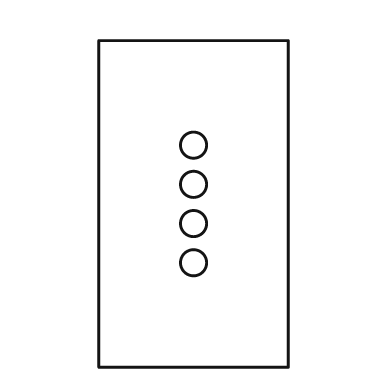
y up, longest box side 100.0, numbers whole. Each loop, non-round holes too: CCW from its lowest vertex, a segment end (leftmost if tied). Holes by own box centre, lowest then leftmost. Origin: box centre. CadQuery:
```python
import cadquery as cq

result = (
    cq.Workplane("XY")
    .moveTo(-29.0, -50.0)
    .lineTo(29.0, -50.0)
    .lineTo(29.0, 50.0)
    .lineTo(-29.0, 50.0)
    .close()
    .moveTo(0.0, -18.0)
    .circle(4.0)
    .moveTo(0.0, -6.0)
    .circle(4.0)
    .moveTo(0.0, 6.0)
    .circle(4.0)
    .moveTo(0.0, 18.0)
    .circle(4.0)
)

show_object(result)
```